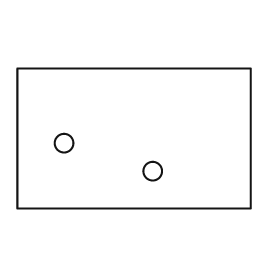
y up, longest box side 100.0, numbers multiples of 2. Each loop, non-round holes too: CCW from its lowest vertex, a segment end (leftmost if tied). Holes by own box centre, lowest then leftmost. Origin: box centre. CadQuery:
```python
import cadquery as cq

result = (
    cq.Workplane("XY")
    .moveTo(-50.0, -30.0)
    .lineTo(50.0, -30.0)
    .lineTo(50.0, 30.0)
    .lineTo(-50.0, 30.0)
    .close()
    .moveTo(8.0, -14.0)
    .circle(4.0)
    .moveTo(-30.0, -2.0)
    .circle(4.0)
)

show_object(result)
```